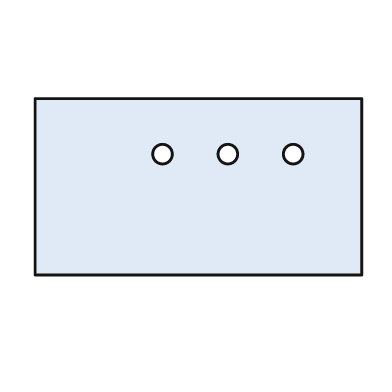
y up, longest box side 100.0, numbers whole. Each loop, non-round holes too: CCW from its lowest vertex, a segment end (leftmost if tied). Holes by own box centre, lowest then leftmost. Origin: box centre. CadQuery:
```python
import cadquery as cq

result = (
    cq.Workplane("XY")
    .moveTo(-50.0, -27.0)
    .lineTo(50.0, -27.0)
    .lineTo(50.0, 27.0)
    .lineTo(-50.0, 27.0)
    .close()
    .moveTo(-11.0, 10.0)
    .circle(3.0)
    .moveTo(9.0, 10.0)
    .circle(3.0)
    .moveTo(29.0, 10.0)
    .circle(3.0)
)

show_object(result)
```